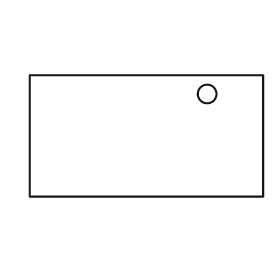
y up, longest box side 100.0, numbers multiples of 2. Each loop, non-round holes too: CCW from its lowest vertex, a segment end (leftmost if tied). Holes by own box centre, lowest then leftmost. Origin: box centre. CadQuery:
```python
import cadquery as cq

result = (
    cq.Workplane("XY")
    .moveTo(-50.0, -26.0)
    .lineTo(50.0, -26.0)
    .lineTo(50.0, 26.0)
    .lineTo(-50.0, 26.0)
    .close()
    .moveTo(26.0, 18.0)
    .circle(4.0)
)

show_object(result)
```